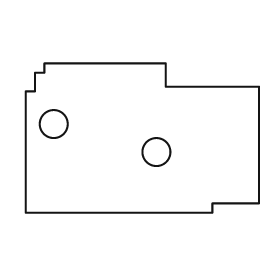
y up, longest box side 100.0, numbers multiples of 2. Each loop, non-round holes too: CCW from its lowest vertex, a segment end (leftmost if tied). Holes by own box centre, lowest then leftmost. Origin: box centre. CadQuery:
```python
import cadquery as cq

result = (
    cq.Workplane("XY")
    .moveTo(-50.0, -32.0)
    .lineTo(30.0, -32.0)
    .lineTo(30.0, -28.0)
    .lineTo(50.0, -28.0)
    .lineTo(50.0, 22.0)
    .lineTo(10.0, 22.0)
    .lineTo(10.0, 32.0)
    .lineTo(-42.0, 32.0)
    .lineTo(-42.0, 28.0)
    .lineTo(-46.0, 28.0)
    .lineTo(-46.0, 20.0)
    .lineTo(-50.0, 20.0)
    .close()
    .moveTo(6.0, -6.0)
    .circle(6.0)
    .moveTo(-38.0, 6.0)
    .circle(6.0)
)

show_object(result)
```